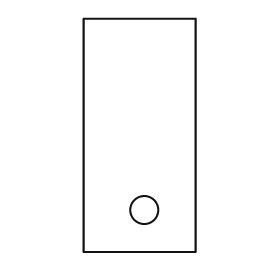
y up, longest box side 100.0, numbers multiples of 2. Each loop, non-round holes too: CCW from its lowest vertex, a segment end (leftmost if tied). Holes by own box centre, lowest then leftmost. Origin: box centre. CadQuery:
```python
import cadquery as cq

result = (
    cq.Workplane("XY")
    .moveTo(-24.0, -50.0)
    .lineTo(24.0, -50.0)
    .lineTo(24.0, 50.0)
    .lineTo(-24.0, 50.0)
    .close()
    .moveTo(2.0, -32.0)
    .circle(6.0)
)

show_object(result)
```